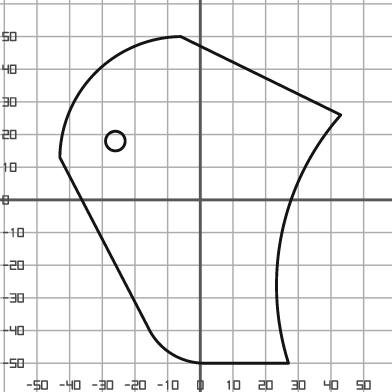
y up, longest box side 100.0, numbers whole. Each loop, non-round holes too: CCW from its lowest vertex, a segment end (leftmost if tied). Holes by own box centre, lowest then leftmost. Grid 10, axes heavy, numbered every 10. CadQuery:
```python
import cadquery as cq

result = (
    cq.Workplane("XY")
    .moveTo(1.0, -50.0)
    .lineTo(27.0, -50.0)
    .threePointArc((25.0, -10.0), (43.0, 26.0))
    .lineTo(-6.0, 50.0)
    .threePointArc((-32.0, 39.0), (-43.0, 13.0))
    .lineTo(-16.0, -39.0)
    .threePointArc((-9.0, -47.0), (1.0, -50.0))
    .close()
    .moveTo(-26.0, 18.0)
    .circle(3.0)
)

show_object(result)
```